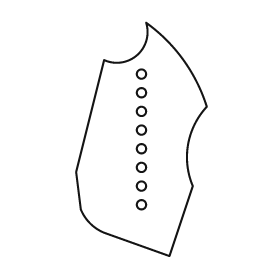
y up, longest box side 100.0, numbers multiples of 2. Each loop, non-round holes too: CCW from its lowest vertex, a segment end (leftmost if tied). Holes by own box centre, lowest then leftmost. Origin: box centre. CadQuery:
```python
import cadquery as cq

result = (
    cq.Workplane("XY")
    .moveTo(12.0, -50.0)
    .lineTo(22.0, -20.0)
    .threePointArc((20.0, -2.0), (28.0, 14.0))
    .threePointArc((18.0, 34.0), (2.0, 50.0))
    .threePointArc((-2.0, 36.0), (-16.0, 34.0))
    .lineTo(-28.0, -14.0)
    .lineTo(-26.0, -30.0)
    .threePointArc((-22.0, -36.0), (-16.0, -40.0))
    .close()
    .moveTo(0.0, -28.0)
    .circle(2.0)
    .moveTo(0.0, -20.0)
    .circle(2.0)
    .moveTo(0.0, -12.0)
    .circle(2.0)
    .moveTo(0.0, -4.0)
    .circle(2.0)
    .moveTo(0.0, 4.0)
    .circle(2.0)
    .moveTo(0.0, 12.0)
    .circle(2.0)
    .moveTo(0.0, 20.0)
    .circle(2.0)
    .moveTo(0.0, 28.0)
    .circle(2.0)
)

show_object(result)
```